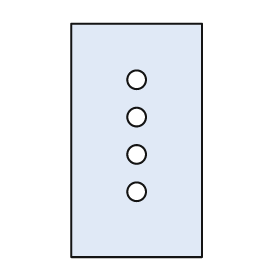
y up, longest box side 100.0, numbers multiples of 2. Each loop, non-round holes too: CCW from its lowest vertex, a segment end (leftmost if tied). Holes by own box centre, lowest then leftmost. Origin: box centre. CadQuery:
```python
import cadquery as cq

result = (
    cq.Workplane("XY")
    .moveTo(-28.0, -50.0)
    .lineTo(28.0, -50.0)
    .lineTo(28.0, 50.0)
    .lineTo(-28.0, 50.0)
    .close()
    .moveTo(0.0, -22.0)
    .circle(4.0)
    .moveTo(0.0, -6.0)
    .circle(4.0)
    .moveTo(0.0, 10.0)
    .circle(4.0)
    .moveTo(0.0, 26.0)
    .circle(4.0)
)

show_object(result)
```